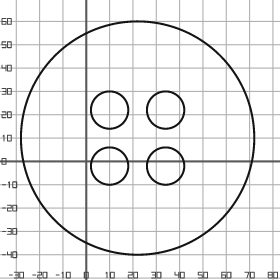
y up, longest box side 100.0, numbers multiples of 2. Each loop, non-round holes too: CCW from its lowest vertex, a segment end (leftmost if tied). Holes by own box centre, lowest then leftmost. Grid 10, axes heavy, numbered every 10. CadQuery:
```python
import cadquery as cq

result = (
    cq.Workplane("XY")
    .moveTo(22.0, 10.0)
    .circle(50.0)
    .moveTo(10.0, -2.0)
    .circle(8.0)
    .moveTo(34.0, -2.0)
    .circle(8.0)
    .moveTo(10.0, 22.0)
    .circle(8.0)
    .moveTo(34.0, 22.0)
    .circle(8.0)
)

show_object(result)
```